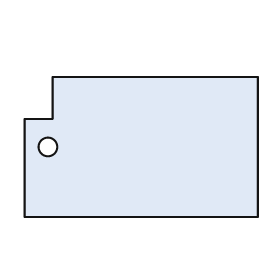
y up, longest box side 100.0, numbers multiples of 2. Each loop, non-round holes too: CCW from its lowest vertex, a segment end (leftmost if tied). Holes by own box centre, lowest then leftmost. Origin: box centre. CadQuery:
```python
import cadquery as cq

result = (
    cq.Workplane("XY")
    .moveTo(-50.0, -30.0)
    .lineTo(50.0, -30.0)
    .lineTo(50.0, 30.0)
    .lineTo(-38.0, 30.0)
    .lineTo(-38.0, 12.0)
    .lineTo(-50.0, 12.0)
    .close()
    .moveTo(-40.0, 0.0)
    .circle(4.0)
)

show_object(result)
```